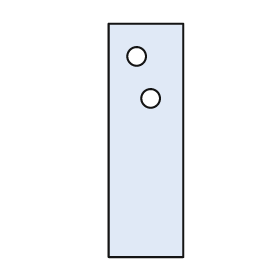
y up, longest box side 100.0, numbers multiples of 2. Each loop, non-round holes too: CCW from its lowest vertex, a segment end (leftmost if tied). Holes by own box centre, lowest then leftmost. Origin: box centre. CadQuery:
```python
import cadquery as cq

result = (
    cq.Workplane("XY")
    .moveTo(-16.0, -50.0)
    .lineTo(16.0, -50.0)
    .lineTo(16.0, 50.0)
    .lineTo(-16.0, 50.0)
    .close()
    .moveTo(2.0, 18.0)
    .circle(4.0)
    .moveTo(-4.0, 36.0)
    .circle(4.0)
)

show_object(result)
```